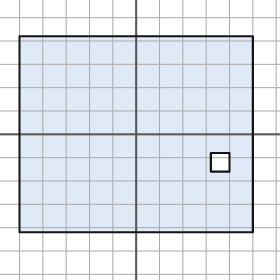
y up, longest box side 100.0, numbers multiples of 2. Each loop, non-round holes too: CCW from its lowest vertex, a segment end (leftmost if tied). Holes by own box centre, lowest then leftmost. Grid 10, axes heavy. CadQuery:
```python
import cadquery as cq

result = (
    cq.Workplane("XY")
    .moveTo(-50.0, -42.0)
    .lineTo(50.0, -42.0)
    .lineTo(50.0, 42.0)
    .lineTo(-50.0, 42.0)
    .close()
    .moveTo(32.0, -16.0)
    .lineTo(40.0, -16.0)
    .lineTo(40.0, -8.0)
    .lineTo(32.0, -8.0)
    .close()
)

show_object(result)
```